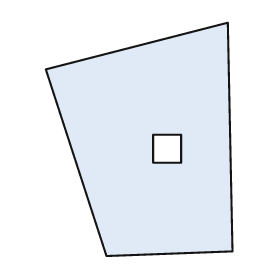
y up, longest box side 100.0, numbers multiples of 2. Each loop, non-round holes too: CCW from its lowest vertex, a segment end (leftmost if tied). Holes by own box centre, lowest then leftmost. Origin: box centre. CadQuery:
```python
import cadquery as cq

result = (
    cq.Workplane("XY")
    .moveTo(-14.0, -50.0)
    .lineTo(40.0, -48.0)
    .lineTo(38.0, 50.0)
    .lineTo(-40.0, 30.0)
    .close()
    .moveTo(6.0, -10.0)
    .lineTo(18.0, -10.0)
    .lineTo(18.0, 2.0)
    .lineTo(6.0, 2.0)
    .close()
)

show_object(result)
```